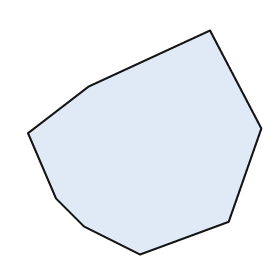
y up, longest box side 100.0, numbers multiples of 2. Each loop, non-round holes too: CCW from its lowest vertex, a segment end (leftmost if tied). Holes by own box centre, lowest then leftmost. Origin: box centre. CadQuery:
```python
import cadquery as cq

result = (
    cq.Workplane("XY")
    .moveTo(-2.0, -48.0)
    .lineTo(36.0, -34.0)
    .lineTo(50.0, 6.0)
    .lineTo(28.0, 48.0)
    .lineTo(-24.0, 24.0)
    .lineTo(-50.0, 4.0)
    .lineTo(-38.0, -24.0)
    .lineTo(-26.0, -36.0)
    .close()
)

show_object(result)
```